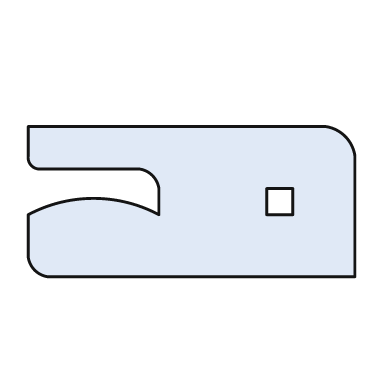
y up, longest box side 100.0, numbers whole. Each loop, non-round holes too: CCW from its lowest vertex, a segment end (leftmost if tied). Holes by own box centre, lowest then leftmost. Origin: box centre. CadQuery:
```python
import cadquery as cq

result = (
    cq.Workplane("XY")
    .moveTo(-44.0, -23.0)
    .lineTo(50.0, -23.0)
    .lineTo(50.0, 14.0)
    .threePointArc((47.0, 20.0), (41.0, 23.0))
    .lineTo(-50.0, 23.0)
    .lineTo(-50.0, 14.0)
    .threePointArc((-49.0, 11.0), (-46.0, 10.0))
    .lineTo(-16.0, 10.0)
    .threePointArc((-12.0, 8.0), (-10.0, 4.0))
    .lineTo(-10.0, -4.0)
    .threePointArc((-30.0, 1.0), (-50.0, -4.0))
    .lineTo(-50.0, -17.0)
    .threePointArc((-48.0, -21.0), (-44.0, -23.0))
    .close()
    .moveTo(23.0, -4.0)
    .lineTo(31.0, -4.0)
    .lineTo(31.0, 4.0)
    .lineTo(23.0, 4.0)
    .close()
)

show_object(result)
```